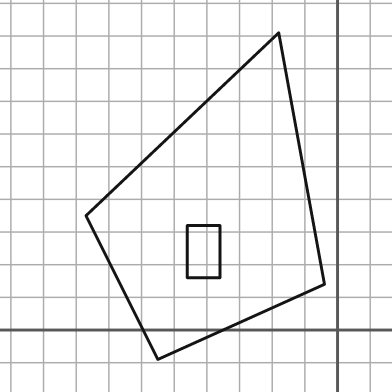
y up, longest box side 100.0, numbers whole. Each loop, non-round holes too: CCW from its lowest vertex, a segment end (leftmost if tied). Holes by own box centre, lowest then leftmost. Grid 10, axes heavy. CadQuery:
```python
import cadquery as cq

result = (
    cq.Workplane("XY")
    .moveTo(-55.0, -9.0)
    .lineTo(-4.0, 14.0)
    .lineTo(-18.0, 91.0)
    .lineTo(-77.0, 35.0)
    .close()
    .moveTo(-46.0, 16.0)
    .lineTo(-36.0, 16.0)
    .lineTo(-36.0, 32.0)
    .lineTo(-46.0, 32.0)
    .close()
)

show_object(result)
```